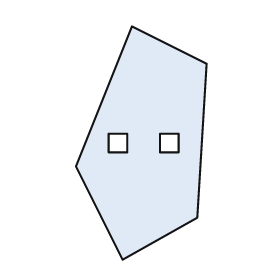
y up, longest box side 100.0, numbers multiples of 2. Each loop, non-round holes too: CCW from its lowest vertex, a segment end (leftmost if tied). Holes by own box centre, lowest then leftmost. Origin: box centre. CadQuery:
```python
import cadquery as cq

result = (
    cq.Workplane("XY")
    .moveTo(-8.0, -50.0)
    .lineTo(24.0, -32.0)
    .lineTo(28.0, 34.0)
    .lineTo(-4.0, 50.0)
    .lineTo(-28.0, -10.0)
    .close()
    .moveTo(-14.0, -4.0)
    .lineTo(-6.0, -4.0)
    .lineTo(-6.0, 4.0)
    .lineTo(-14.0, 4.0)
    .close()
    .moveTo(8.0, -4.0)
    .lineTo(16.0, -4.0)
    .lineTo(16.0, 4.0)
    .lineTo(8.0, 4.0)
    .close()
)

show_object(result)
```